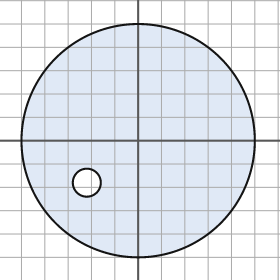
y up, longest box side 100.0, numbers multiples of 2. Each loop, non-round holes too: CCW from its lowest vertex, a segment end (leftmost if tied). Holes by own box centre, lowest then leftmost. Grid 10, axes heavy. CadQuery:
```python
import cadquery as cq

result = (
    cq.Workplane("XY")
    .moveTo(0.0, 0.0)
    .circle(50.0)
    .moveTo(-22.0, -18.0)
    .circle(6.0)
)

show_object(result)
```